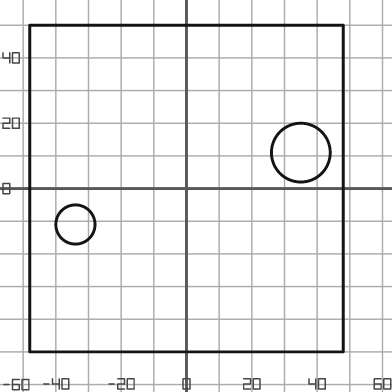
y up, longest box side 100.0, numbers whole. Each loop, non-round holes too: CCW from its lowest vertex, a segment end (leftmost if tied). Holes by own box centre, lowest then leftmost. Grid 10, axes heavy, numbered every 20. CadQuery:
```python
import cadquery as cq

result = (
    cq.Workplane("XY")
    .moveTo(-48.0, -50.0)
    .lineTo(48.0, -50.0)
    .lineTo(48.0, 50.0)
    .lineTo(-48.0, 50.0)
    .close()
    .moveTo(-34.0, -11.0)
    .circle(6.0)
    .moveTo(35.0, 11.0)
    .circle(9.0)
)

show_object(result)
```